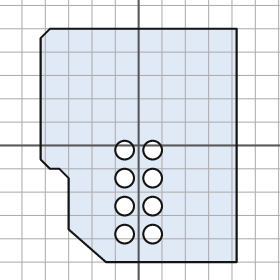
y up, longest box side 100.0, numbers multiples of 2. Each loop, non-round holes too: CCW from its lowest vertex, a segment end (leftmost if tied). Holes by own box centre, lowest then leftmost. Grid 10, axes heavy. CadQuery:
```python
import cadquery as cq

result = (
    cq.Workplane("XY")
    .moveTo(-14.0, -50.0)
    .lineTo(42.0, -50.0)
    .lineTo(42.0, 50.0)
    .lineTo(-38.0, 50.0)
    .lineTo(-42.0, 46.0)
    .lineTo(-42.0, -6.0)
    .lineTo(-38.0, -10.0)
    .lineTo(-34.0, -10.0)
    .lineTo(-30.0, -14.0)
    .lineTo(-30.0, -36.0)
    .close()
    .moveTo(-6.0, -38.0)
    .circle(4.0)
    .moveTo(6.0, -38.0)
    .circle(4.0)
    .moveTo(-6.0, -26.0)
    .circle(4.0)
    .moveTo(6.0, -26.0)
    .circle(4.0)
    .moveTo(-6.0, -14.0)
    .circle(4.0)
    .moveTo(6.0, -14.0)
    .circle(4.0)
    .moveTo(-6.0, -2.0)
    .circle(4.0)
    .moveTo(6.0, -2.0)
    .circle(4.0)
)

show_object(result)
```